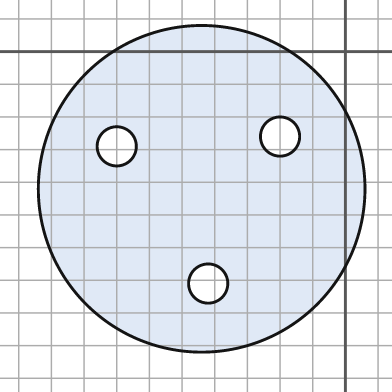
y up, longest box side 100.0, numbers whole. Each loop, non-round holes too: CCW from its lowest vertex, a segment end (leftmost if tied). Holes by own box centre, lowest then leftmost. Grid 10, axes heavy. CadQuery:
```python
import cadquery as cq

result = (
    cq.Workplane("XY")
    .moveTo(-44.0, -42.0)
    .circle(50.0)
    .moveTo(-42.0, -71.0)
    .circle(6.0)
    .moveTo(-70.0, -29.0)
    .circle(6.0)
    .moveTo(-20.0, -26.0)
    .circle(6.0)
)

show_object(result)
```